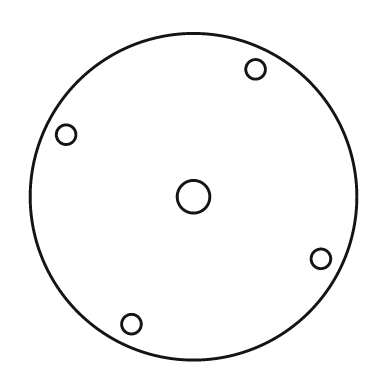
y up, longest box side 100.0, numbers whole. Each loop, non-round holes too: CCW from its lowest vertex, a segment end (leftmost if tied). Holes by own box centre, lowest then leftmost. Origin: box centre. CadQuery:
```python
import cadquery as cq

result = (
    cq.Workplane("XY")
    .moveTo(0.0, 0.0)
    .circle(50.0)
    .moveTo(-19.0, -39.0)
    .circle(3.0)
    .moveTo(39.0, -19.0)
    .circle(3.0)
    .moveTo(0.0, 0.0)
    .circle(5.0)
    .moveTo(-39.0, 19.0)
    .circle(3.0)
    .moveTo(19.0, 39.0)
    .circle(3.0)
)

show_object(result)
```